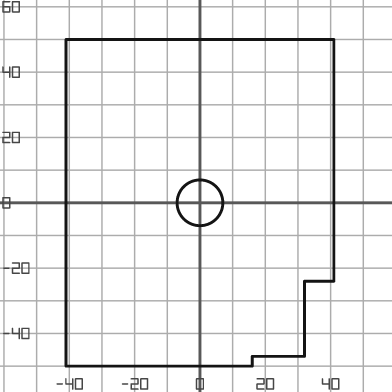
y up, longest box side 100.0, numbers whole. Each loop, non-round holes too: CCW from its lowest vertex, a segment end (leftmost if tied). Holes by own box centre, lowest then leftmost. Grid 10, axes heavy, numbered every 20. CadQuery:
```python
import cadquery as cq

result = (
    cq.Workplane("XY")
    .moveTo(-41.0, -50.0)
    .lineTo(16.0, -50.0)
    .lineTo(16.0, -47.0)
    .lineTo(32.0, -47.0)
    .lineTo(32.0, -24.0)
    .lineTo(41.0, -24.0)
    .lineTo(41.0, 50.0)
    .lineTo(-41.0, 50.0)
    .close()
    .moveTo(0.0, 0.0)
    .circle(7.0)
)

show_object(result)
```